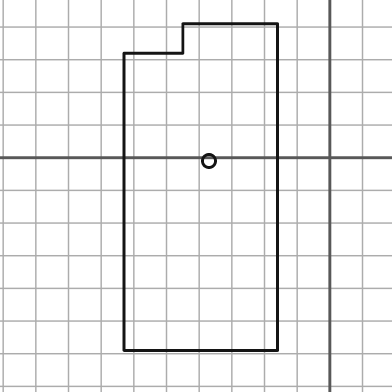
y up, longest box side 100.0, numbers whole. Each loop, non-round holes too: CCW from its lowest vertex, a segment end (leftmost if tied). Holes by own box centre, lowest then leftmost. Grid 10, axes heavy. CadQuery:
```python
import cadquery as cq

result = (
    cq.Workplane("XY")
    .moveTo(-63.0, -59.0)
    .lineTo(-16.0, -59.0)
    .lineTo(-16.0, 41.0)
    .lineTo(-45.0, 41.0)
    .lineTo(-45.0, 32.0)
    .lineTo(-63.0, 32.0)
    .close()
    .moveTo(-37.0, -1.0)
    .circle(2.0)
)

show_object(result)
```